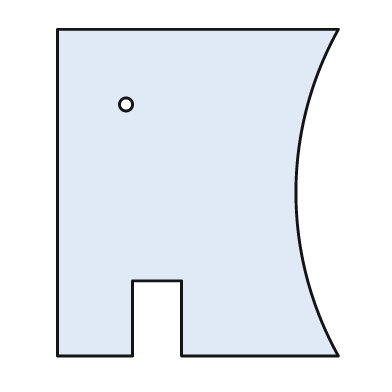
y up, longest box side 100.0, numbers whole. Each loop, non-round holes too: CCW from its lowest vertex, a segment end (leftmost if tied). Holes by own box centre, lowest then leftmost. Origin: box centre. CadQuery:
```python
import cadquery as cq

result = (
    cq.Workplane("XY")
    .moveTo(-43.0, -50.0)
    .lineTo(-20.0, -50.0)
    .lineTo(-20.0, -27.0)
    .lineTo(-5.0, -27.0)
    .lineTo(-5.0, -50.0)
    .lineTo(43.0, -50.0)
    .threePointArc((30.0, 0.0), (43.0, 50.0))
    .lineTo(-43.0, 50.0)
    .close()
    .moveTo(-22.0, 27.0)
    .circle(2.0)
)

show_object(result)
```